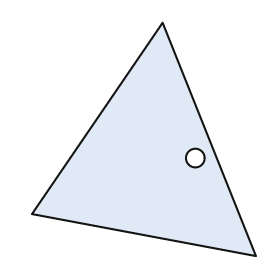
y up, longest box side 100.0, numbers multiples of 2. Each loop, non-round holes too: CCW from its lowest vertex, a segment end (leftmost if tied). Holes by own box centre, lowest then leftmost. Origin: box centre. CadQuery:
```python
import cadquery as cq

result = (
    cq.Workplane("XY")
    .moveTo(48.0, -50.0)
    .lineTo(8.0, 50.0)
    .lineTo(-48.0, -32.0)
    .close()
    .moveTo(22.0, -8.0)
    .circle(4.0)
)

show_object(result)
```